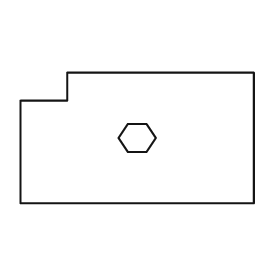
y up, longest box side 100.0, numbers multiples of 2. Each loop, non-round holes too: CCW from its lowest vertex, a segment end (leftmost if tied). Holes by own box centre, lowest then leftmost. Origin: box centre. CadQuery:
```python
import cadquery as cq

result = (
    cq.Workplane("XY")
    .moveTo(-50.0, -28.0)
    .lineTo(50.0, -28.0)
    .lineTo(50.0, 28.0)
    .lineTo(-30.0, 28.0)
    .lineTo(-30.0, 16.0)
    .lineTo(-50.0, 16.0)
    .close()
    .moveTo(-4.0, -6.0)
    .lineTo(4.0, -6.0)
    .lineTo(8.0, 0.0)
    .lineTo(4.0, 6.0)
    .lineTo(-4.0, 6.0)
    .lineTo(-8.0, 0.0)
    .close()
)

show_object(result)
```